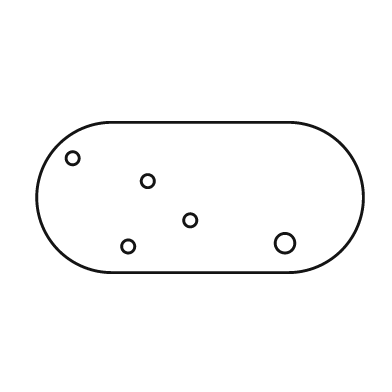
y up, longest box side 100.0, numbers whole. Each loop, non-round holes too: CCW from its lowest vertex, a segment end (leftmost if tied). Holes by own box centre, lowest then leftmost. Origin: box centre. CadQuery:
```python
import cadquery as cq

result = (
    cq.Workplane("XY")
    .moveTo(-27.0, -23.0)
    .lineTo(27.0, -23.0)
    .threePointArc((50.0, 0.0), (27.0, 23.0))
    .lineTo(-27.0, 23.0)
    .threePointArc((-50.0, 0.0), (-27.0, -23.0))
    .close()
    .moveTo(-22.0, -15.0)
    .circle(2.0)
    .moveTo(26.0, -14.0)
    .circle(3.0)
    .moveTo(-3.0, -7.0)
    .circle(2.0)
    .moveTo(-16.0, 5.0)
    .circle(2.0)
    .moveTo(-39.0, 12.0)
    .circle(2.0)
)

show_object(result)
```